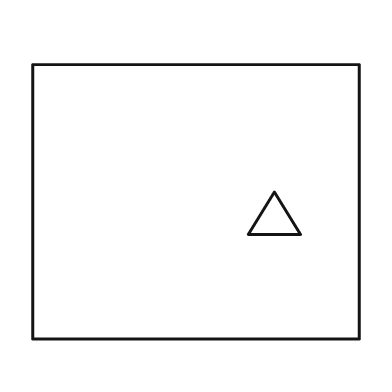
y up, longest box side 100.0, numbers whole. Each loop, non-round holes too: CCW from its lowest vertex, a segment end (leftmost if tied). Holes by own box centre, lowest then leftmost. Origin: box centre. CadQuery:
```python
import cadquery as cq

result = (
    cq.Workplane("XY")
    .moveTo(-50.0, -42.0)
    .lineTo(50.0, -42.0)
    .lineTo(50.0, 42.0)
    .lineTo(-50.0, 42.0)
    .close()
    .moveTo(16.0, -10.0)
    .lineTo(32.0, -10.0)
    .lineTo(24.0, 3.0)
    .close()
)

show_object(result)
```